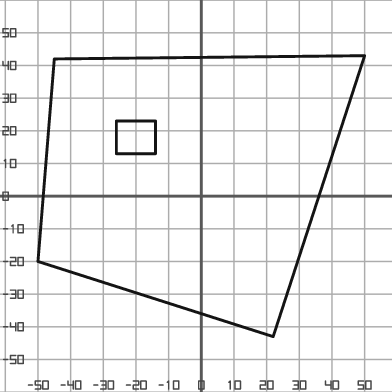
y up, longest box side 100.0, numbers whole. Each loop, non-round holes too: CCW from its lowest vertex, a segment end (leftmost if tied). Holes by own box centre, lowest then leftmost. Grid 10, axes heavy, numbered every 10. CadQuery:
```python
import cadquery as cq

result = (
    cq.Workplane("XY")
    .moveTo(22.0, -43.0)
    .lineTo(50.0, 43.0)
    .lineTo(-45.0, 42.0)
    .lineTo(-50.0, -20.0)
    .close()
    .moveTo(-26.0, 13.0)
    .lineTo(-14.0, 13.0)
    .lineTo(-14.0, 23.0)
    .lineTo(-26.0, 23.0)
    .close()
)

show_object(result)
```